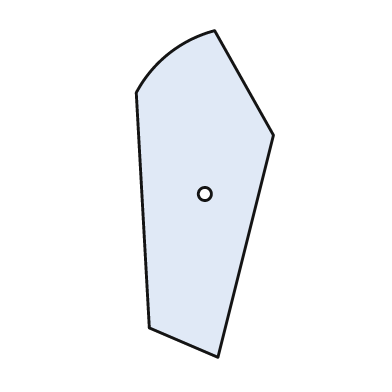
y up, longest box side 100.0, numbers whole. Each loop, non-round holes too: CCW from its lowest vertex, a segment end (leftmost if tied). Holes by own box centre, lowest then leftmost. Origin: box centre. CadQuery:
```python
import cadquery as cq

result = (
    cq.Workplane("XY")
    .moveTo(4.0, -50.0)
    .lineTo(21.0, 18.0)
    .lineTo(3.0, 50.0)
    .threePointArc((-11.0, 43.0), (-21.0, 31.0))
    .lineTo(-17.0, -41.0)
    .close()
    .moveTo(0.0, 0.0)
    .circle(2.0)
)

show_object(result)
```